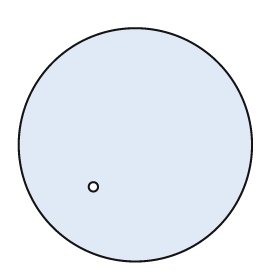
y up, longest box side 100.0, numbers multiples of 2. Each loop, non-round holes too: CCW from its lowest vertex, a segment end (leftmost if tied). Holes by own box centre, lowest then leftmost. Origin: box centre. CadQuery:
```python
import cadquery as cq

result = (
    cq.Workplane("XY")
    .moveTo(0.0, 0.0)
    .circle(50.0)
    .moveTo(-18.0, -18.0)
    .circle(2.0)
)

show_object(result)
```